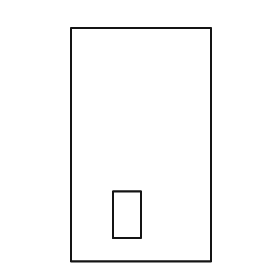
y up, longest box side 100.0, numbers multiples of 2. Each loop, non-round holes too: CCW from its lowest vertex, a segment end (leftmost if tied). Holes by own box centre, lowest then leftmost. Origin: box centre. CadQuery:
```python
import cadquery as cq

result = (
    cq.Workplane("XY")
    .moveTo(-30.0, -50.0)
    .lineTo(30.0, -50.0)
    .lineTo(30.0, 50.0)
    .lineTo(-30.0, 50.0)
    .close()
    .moveTo(-12.0, -40.0)
    .lineTo(0.0, -40.0)
    .lineTo(0.0, -20.0)
    .lineTo(-12.0, -20.0)
    .close()
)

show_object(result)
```